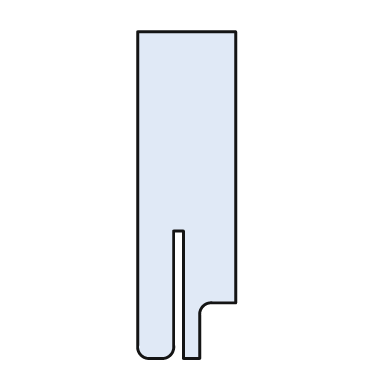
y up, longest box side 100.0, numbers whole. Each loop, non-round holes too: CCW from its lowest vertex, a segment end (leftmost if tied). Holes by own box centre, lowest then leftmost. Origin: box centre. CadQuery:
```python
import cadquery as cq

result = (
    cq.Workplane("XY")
    .moveTo(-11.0, -50.0)
    .lineTo(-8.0, -50.0)
    .threePointArc((-5.0, -49.0), (-4.0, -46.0))
    .lineTo(-4.0, -11.0)
    .lineTo(-1.0, -11.0)
    .lineTo(-1.0, -50.0)
    .lineTo(4.0, -50.0)
    .lineTo(4.0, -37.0)
    .threePointArc((5.0, -34.0), (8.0, -33.0))
    .lineTo(15.0, -33.0)
    .lineTo(15.0, 50.0)
    .lineTo(-15.0, 50.0)
    .lineTo(-15.0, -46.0)
    .threePointArc((-14.0, -49.0), (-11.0, -50.0))
    .close()
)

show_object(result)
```